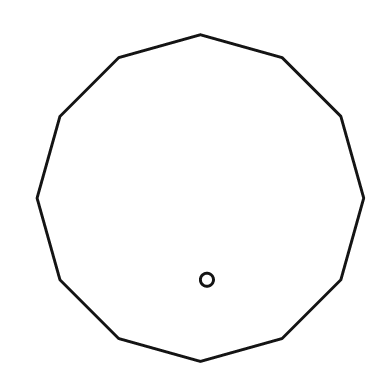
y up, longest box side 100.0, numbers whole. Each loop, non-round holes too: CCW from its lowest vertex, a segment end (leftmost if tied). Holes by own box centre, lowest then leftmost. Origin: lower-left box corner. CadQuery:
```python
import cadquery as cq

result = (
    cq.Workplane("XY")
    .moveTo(50.0, 0.0)
    .lineTo(75.0, 7.0)
    .lineTo(93.0, 25.0)
    .lineTo(100.0, 50.0)
    .lineTo(93.0, 75.0)
    .lineTo(75.0, 93.0)
    .lineTo(50.0, 100.0)
    .lineTo(25.0, 93.0)
    .lineTo(7.0, 75.0)
    .lineTo(0.0, 50.0)
    .lineTo(7.0, 25.0)
    .lineTo(25.0, 7.0)
    .close()
    .moveTo(52.0, 25.0)
    .circle(2.0)
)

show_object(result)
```